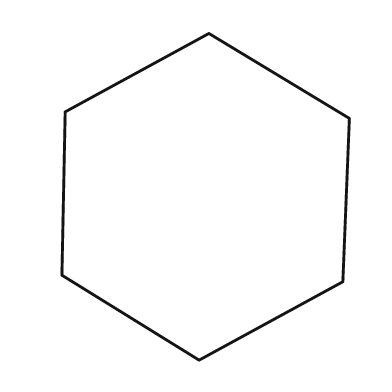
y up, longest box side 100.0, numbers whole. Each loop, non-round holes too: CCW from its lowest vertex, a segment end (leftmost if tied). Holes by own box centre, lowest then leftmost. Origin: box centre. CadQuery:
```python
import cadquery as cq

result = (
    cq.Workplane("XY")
    .moveTo(-2.0, -50.0)
    .lineTo(42.0, -26.0)
    .lineTo(44.0, 24.0)
    .lineTo(1.0, 50.0)
    .lineTo(-43.0, 26.0)
    .lineTo(-44.0, -24.0)
    .close()
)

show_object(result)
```